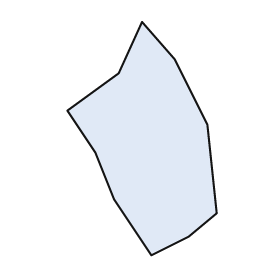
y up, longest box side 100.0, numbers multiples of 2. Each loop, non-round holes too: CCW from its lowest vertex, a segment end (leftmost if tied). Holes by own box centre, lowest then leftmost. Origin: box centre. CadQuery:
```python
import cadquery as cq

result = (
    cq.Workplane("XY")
    .moveTo(4.0, -50.0)
    .lineTo(20.0, -42.0)
    .lineTo(32.0, -32.0)
    .lineTo(28.0, 6.0)
    .lineTo(14.0, 34.0)
    .lineTo(0.0, 50.0)
    .lineTo(-10.0, 28.0)
    .lineTo(-32.0, 12.0)
    .lineTo(-20.0, -6.0)
    .lineTo(-12.0, -26.0)
    .close()
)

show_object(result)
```